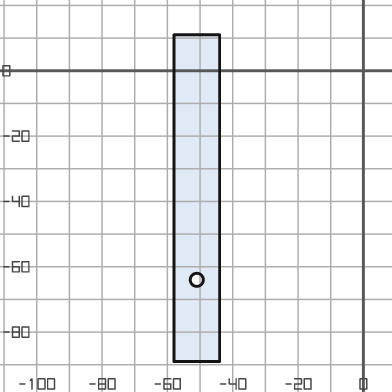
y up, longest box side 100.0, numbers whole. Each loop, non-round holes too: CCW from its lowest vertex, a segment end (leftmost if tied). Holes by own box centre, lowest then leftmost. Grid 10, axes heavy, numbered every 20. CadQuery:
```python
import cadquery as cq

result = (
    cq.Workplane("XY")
    .moveTo(-58.0, -89.0)
    .lineTo(-44.0, -89.0)
    .lineTo(-44.0, 11.0)
    .lineTo(-58.0, 11.0)
    .close()
    .moveTo(-51.0, -64.0)
    .circle(2.0)
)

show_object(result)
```